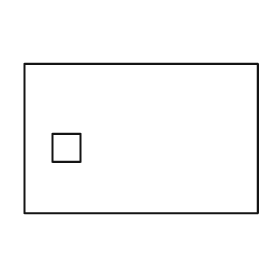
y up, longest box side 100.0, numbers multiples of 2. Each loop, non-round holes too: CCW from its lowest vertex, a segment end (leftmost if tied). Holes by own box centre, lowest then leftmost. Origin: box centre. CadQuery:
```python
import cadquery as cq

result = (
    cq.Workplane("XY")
    .moveTo(-50.0, -32.0)
    .lineTo(50.0, -32.0)
    .lineTo(50.0, 32.0)
    .lineTo(-50.0, 32.0)
    .close()
    .moveTo(-38.0, -10.0)
    .lineTo(-26.0, -10.0)
    .lineTo(-26.0, 2.0)
    .lineTo(-38.0, 2.0)
    .close()
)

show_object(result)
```